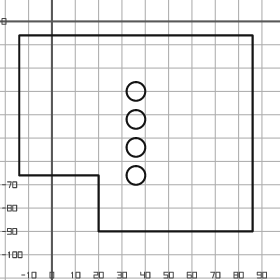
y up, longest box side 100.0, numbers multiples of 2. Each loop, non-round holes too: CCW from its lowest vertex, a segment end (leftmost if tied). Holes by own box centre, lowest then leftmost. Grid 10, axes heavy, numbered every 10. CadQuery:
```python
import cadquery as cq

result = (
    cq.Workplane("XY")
    .moveTo(20.0, -90.0)
    .lineTo(86.0, -90.0)
    .lineTo(86.0, -6.0)
    .lineTo(-14.0, -6.0)
    .lineTo(-14.0, -66.0)
    .lineTo(20.0, -66.0)
    .close()
    .moveTo(36.0, -66.0)
    .circle(4.0)
    .moveTo(36.0, -54.0)
    .circle(4.0)
    .moveTo(36.0, -42.0)
    .circle(4.0)
    .moveTo(36.0, -30.0)
    .circle(4.0)
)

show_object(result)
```